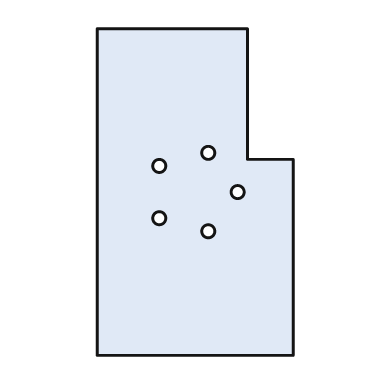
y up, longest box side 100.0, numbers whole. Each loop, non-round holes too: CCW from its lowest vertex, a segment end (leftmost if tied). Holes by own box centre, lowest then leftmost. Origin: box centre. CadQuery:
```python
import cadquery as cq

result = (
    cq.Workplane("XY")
    .moveTo(-30.0, -50.0)
    .lineTo(30.0, -50.0)
    .lineTo(30.0, 10.0)
    .lineTo(16.0, 10.0)
    .lineTo(16.0, 50.0)
    .lineTo(-30.0, 50.0)
    .close()
    .moveTo(4.0, -12.0)
    .circle(2.0)
    .moveTo(-11.0, -8.0)
    .circle(2.0)
    .moveTo(13.0, 0.0)
    .circle(2.0)
    .moveTo(-11.0, 8.0)
    .circle(2.0)
    .moveTo(4.0, 12.0)
    .circle(2.0)
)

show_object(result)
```